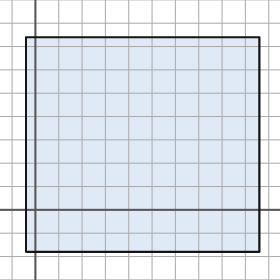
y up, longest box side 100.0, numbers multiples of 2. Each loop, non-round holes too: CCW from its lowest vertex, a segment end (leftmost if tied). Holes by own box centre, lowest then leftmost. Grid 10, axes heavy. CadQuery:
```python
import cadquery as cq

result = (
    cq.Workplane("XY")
    .moveTo(-4.0, -18.0)
    .lineTo(96.0, -18.0)
    .lineTo(96.0, 74.0)
    .lineTo(-4.0, 74.0)
    .close()
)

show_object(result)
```